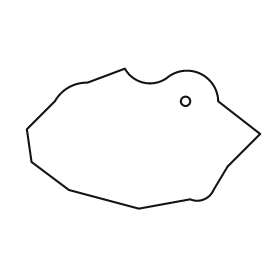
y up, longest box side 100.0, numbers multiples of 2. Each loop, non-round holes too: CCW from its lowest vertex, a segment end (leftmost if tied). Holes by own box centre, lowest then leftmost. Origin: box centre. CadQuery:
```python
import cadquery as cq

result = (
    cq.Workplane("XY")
    .moveTo(-2.0, -30.0)
    .lineTo(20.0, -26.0)
    .threePointArc((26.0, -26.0), (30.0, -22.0))
    .lineTo(36.0, -12.0)
    .lineTo(50.0, 2.0)
    .lineTo(32.0, 16.0)
    .threePointArc((24.0, 28.0), (10.0, 26.0))
    .threePointArc((0.0, 24.0), (-8.0, 30.0))
    .lineTo(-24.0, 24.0)
    .threePointArc((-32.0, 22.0), (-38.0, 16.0))
    .lineTo(-50.0, 4.0)
    .lineTo(-48.0, -10.0)
    .lineTo(-32.0, -22.0)
    .close()
    .moveTo(18.0, 16.0)
    .circle(2.0)
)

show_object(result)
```